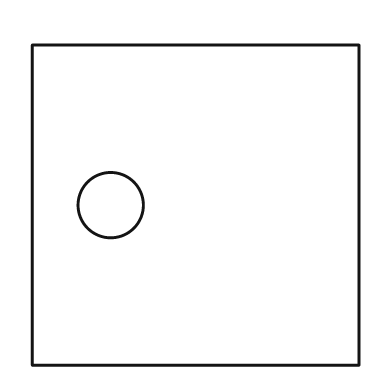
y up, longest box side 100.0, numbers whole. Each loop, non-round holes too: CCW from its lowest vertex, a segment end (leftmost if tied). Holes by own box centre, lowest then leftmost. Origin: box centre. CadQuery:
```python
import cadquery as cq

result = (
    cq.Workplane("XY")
    .moveTo(-50.0, -49.0)
    .lineTo(50.0, -49.0)
    .lineTo(50.0, 49.0)
    .lineTo(-50.0, 49.0)
    .close()
    .moveTo(-26.0, 0.0)
    .circle(10.0)
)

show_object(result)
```